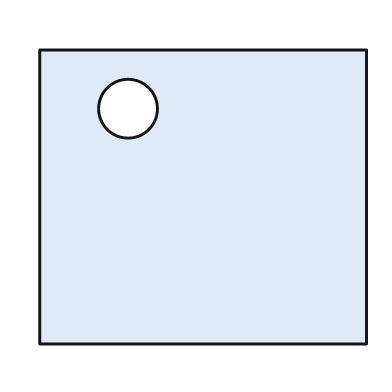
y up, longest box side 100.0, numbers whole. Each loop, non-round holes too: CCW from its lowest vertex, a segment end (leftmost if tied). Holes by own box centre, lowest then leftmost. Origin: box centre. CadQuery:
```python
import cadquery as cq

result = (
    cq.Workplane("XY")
    .moveTo(-50.0, -45.0)
    .lineTo(50.0, -45.0)
    .lineTo(50.0, 45.0)
    .lineTo(-50.0, 45.0)
    .close()
    .moveTo(-23.0, 27.0)
    .circle(9.0)
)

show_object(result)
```